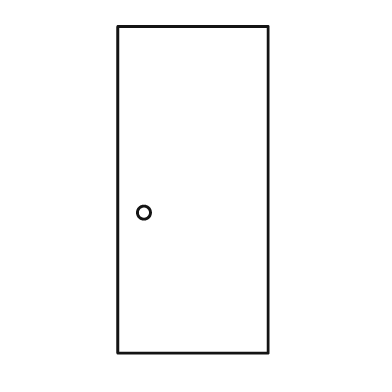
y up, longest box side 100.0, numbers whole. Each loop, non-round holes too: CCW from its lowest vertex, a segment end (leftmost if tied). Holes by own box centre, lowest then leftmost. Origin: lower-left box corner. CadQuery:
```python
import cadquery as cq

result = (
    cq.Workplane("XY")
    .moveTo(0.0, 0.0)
    .lineTo(46.0, 0.0)
    .lineTo(46.0, 100.0)
    .lineTo(0.0, 100.0)
    .close()
    .moveTo(8.0, 43.0)
    .circle(2.0)
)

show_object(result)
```